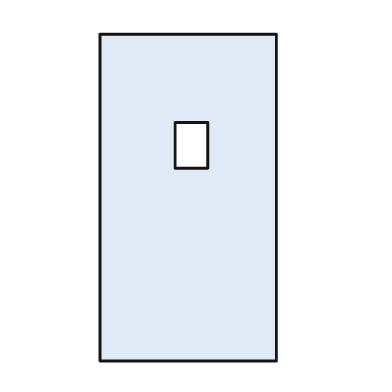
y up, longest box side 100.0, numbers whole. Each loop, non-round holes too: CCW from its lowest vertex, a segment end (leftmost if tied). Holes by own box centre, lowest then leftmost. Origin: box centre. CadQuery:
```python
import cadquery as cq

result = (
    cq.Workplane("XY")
    .moveTo(-27.0, -50.0)
    .lineTo(27.0, -50.0)
    .lineTo(27.0, 50.0)
    .lineTo(-27.0, 50.0)
    .close()
    .moveTo(-4.0, 9.0)
    .lineTo(6.0, 9.0)
    .lineTo(6.0, 23.0)
    .lineTo(-4.0, 23.0)
    .close()
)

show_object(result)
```